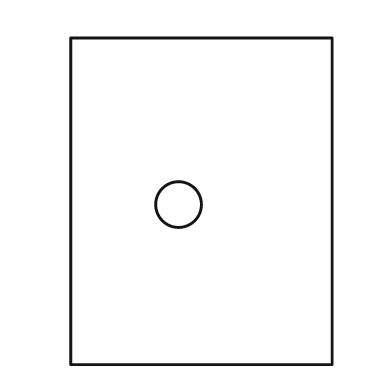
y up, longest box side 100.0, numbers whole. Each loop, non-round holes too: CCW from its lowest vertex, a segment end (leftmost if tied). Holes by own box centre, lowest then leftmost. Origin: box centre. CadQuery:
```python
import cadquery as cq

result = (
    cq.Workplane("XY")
    .moveTo(-40.0, -50.0)
    .lineTo(40.0, -50.0)
    .lineTo(40.0, 50.0)
    .lineTo(-40.0, 50.0)
    .close()
    .moveTo(-7.0, -1.0)
    .circle(7.0)
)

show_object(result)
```